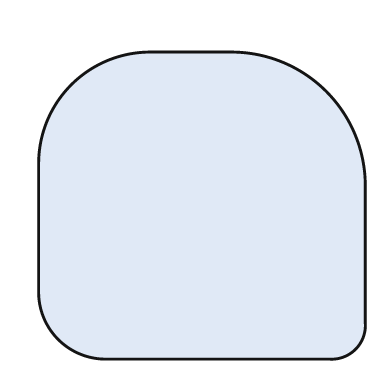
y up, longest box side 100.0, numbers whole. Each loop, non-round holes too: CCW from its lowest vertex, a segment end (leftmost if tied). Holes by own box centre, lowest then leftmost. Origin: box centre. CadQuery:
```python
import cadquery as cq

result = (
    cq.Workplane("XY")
    .moveTo(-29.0, -47.0)
    .lineTo(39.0, -47.0)
    .threePointArc((47.0, -44.0), (50.0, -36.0))
    .lineTo(50.0, 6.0)
    .threePointArc((38.0, 35.0), (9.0, 47.0))
    .lineTo(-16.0, 47.0)
    .threePointArc((-40.0, 37.0), (-50.0, 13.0))
    .lineTo(-50.0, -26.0)
    .threePointArc((-44.0, -41.0), (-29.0, -47.0))
    .close()
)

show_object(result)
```